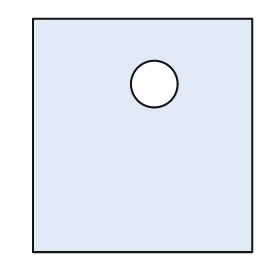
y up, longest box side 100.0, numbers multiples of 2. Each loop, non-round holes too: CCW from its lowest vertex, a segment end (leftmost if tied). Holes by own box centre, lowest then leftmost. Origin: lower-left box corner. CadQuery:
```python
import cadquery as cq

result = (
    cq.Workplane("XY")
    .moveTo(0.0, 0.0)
    .lineTo(94.0, 0.0)
    .lineTo(94.0, 100.0)
    .lineTo(0.0, 100.0)
    .close()
    .moveTo(52.0, 72.0)
    .circle(10.0)
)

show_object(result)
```